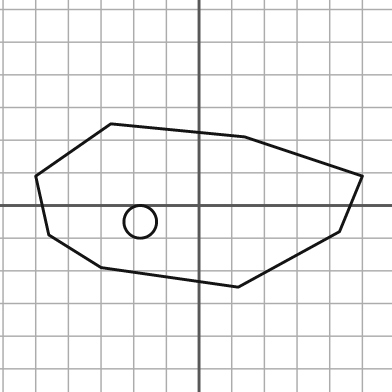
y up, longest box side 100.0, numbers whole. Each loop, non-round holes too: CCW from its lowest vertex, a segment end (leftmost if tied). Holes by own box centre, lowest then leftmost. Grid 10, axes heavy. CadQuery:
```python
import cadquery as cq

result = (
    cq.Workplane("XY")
    .moveTo(12.0, -25.0)
    .lineTo(43.0, -8.0)
    .lineTo(50.0, 9.0)
    .lineTo(14.0, 21.0)
    .lineTo(-27.0, 25.0)
    .lineTo(-50.0, 9.0)
    .lineTo(-46.0, -9.0)
    .lineTo(-30.0, -19.0)
    .close()
    .moveTo(-18.0, -5.0)
    .circle(5.0)
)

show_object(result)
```